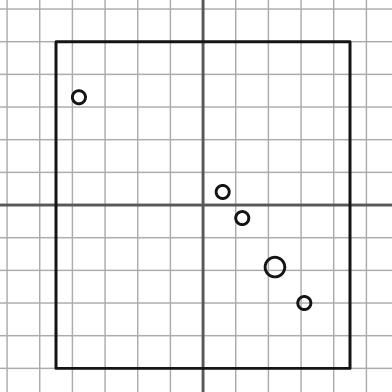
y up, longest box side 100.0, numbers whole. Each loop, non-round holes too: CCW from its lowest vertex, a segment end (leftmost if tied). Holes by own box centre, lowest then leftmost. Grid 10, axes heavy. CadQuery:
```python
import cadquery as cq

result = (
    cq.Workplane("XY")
    .moveTo(-45.0, -50.0)
    .lineTo(45.0, -50.0)
    .lineTo(45.0, 50.0)
    .lineTo(-45.0, 50.0)
    .close()
    .moveTo(31.0, -30.0)
    .circle(2.0)
    .moveTo(22.0, -19.0)
    .circle(3.0)
    .moveTo(12.0, -4.0)
    .circle(2.0)
    .moveTo(6.0, 4.0)
    .circle(2.0)
    .moveTo(-38.0, 33.0)
    .circle(2.0)
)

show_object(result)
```